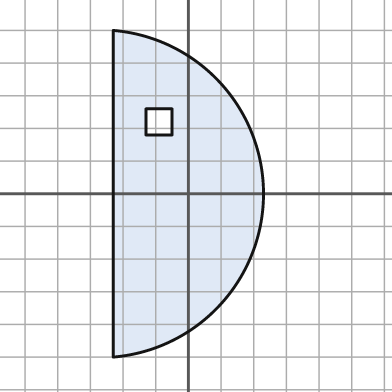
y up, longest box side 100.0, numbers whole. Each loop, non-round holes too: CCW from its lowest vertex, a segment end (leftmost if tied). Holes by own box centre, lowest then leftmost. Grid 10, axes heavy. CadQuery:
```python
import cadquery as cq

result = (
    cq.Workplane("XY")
    .moveTo(-23.0, -50.0)
    .threePointArc((23.0, 0.0), (-23.0, 50.0))
    .close()
    .moveTo(-13.0, 18.0)
    .lineTo(-5.0, 18.0)
    .lineTo(-5.0, 26.0)
    .lineTo(-13.0, 26.0)
    .close()
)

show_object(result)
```